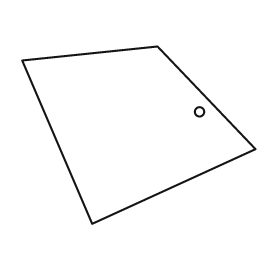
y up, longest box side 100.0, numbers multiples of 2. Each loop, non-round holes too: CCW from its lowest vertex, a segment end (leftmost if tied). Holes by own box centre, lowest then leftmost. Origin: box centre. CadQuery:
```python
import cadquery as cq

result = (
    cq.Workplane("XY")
    .moveTo(-20.0, -38.0)
    .lineTo(50.0, -6.0)
    .lineTo(8.0, 38.0)
    .lineTo(-50.0, 32.0)
    .close()
    .moveTo(26.0, 10.0)
    .circle(2.0)
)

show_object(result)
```